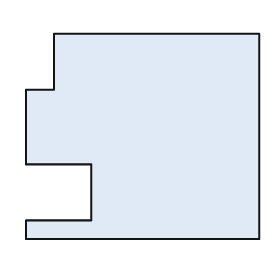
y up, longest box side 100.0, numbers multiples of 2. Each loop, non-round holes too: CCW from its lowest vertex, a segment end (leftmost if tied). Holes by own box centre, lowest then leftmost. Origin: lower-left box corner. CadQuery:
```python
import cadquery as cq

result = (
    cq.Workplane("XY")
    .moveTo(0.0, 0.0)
    .lineTo(100.0, 0.0)
    .lineTo(100.0, 88.0)
    .lineTo(12.0, 88.0)
    .lineTo(12.0, 64.0)
    .lineTo(0.0, 64.0)
    .lineTo(0.0, 32.0)
    .lineTo(28.0, 32.0)
    .lineTo(28.0, 8.0)
    .lineTo(0.0, 8.0)
    .close()
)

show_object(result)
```